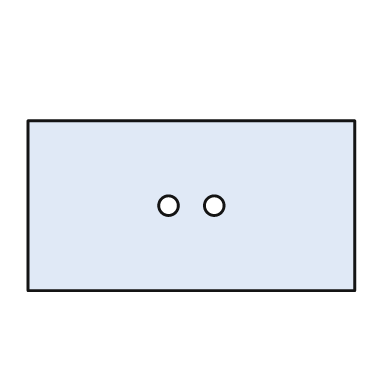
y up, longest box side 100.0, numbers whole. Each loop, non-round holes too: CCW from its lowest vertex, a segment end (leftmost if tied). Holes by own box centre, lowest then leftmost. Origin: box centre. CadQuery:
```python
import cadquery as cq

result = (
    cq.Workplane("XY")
    .moveTo(-50.0, -26.0)
    .lineTo(50.0, -26.0)
    .lineTo(50.0, 26.0)
    .lineTo(-50.0, 26.0)
    .close()
    .moveTo(-7.0, 0.0)
    .circle(3.0)
    .moveTo(7.0, 0.0)
    .circle(3.0)
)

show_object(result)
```